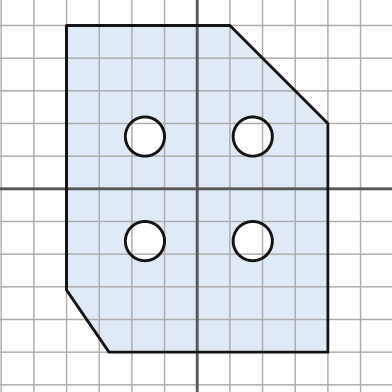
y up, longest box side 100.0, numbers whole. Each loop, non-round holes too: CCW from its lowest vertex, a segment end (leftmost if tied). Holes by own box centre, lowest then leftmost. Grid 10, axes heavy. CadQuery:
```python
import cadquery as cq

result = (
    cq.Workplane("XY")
    .moveTo(-27.0, -50.0)
    .lineTo(40.0, -50.0)
    .lineTo(40.0, 20.0)
    .lineTo(10.0, 50.0)
    .lineTo(-40.0, 50.0)
    .lineTo(-40.0, -31.0)
    .close()
    .moveTo(-16.0, -16.0)
    .circle(6.0)
    .moveTo(17.0, -16.0)
    .circle(6.0)
    .moveTo(-16.0, 16.0)
    .circle(6.0)
    .moveTo(17.0, 16.0)
    .circle(6.0)
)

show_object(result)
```